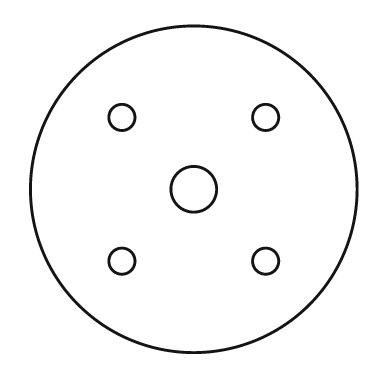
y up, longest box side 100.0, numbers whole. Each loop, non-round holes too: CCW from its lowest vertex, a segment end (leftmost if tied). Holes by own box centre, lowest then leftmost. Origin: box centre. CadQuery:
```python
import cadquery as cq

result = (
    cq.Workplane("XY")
    .moveTo(0.0, 0.0)
    .circle(50.0)
    .moveTo(-22.0, -22.0)
    .circle(4.0)
    .moveTo(22.0, -22.0)
    .circle(4.0)
    .moveTo(0.0, 0.0)
    .circle(7.0)
    .moveTo(-22.0, 22.0)
    .circle(4.0)
    .moveTo(22.0, 22.0)
    .circle(4.0)
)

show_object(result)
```